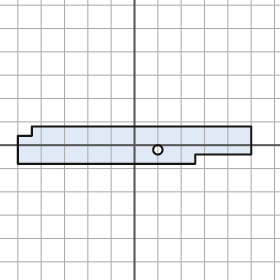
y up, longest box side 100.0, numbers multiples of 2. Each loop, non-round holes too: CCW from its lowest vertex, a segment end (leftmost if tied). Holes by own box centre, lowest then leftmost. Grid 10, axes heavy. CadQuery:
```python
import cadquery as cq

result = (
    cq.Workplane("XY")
    .moveTo(-50.0, -8.0)
    .lineTo(26.0, -8.0)
    .lineTo(26.0, -4.0)
    .lineTo(50.0, -4.0)
    .lineTo(50.0, 8.0)
    .lineTo(-44.0, 8.0)
    .lineTo(-44.0, 4.0)
    .lineTo(-50.0, 4.0)
    .close()
    .moveTo(10.0, -2.0)
    .circle(2.0)
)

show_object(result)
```